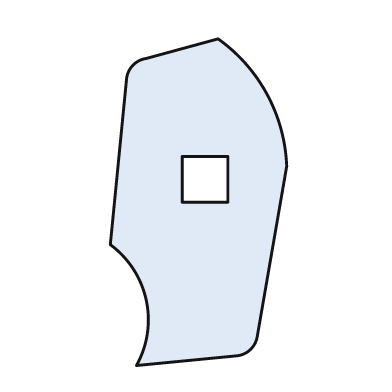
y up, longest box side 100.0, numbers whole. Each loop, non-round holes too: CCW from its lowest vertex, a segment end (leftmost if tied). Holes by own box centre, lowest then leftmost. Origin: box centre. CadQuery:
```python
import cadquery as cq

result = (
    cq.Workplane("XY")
    .moveTo(-19.0, -50.0)
    .lineTo(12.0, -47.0)
    .threePointArc((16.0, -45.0), (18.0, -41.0))
    .lineTo(27.0, 11.0)
    .threePointArc((21.0, 33.0), (6.0, 50.0))
    .lineTo(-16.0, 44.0)
    .threePointArc((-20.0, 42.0), (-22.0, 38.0))
    .lineTo(-27.0, -13.0)
    .threePointArc((-16.0, -30.0), (-19.0, -50.0))
    .close()
    .moveTo(-5.0, 0.0)
    .lineTo(9.0, 0.0)
    .lineTo(9.0, 14.0)
    .lineTo(-5.0, 14.0)
    .close()
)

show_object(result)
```